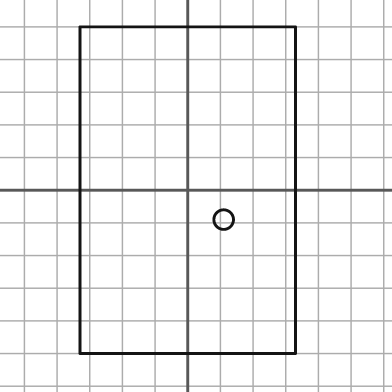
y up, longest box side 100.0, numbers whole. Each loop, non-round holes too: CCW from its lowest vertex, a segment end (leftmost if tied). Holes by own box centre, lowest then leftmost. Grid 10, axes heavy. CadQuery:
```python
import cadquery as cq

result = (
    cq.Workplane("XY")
    .moveTo(-33.0, -50.0)
    .lineTo(33.0, -50.0)
    .lineTo(33.0, 50.0)
    .lineTo(-33.0, 50.0)
    .close()
    .moveTo(11.0, -9.0)
    .circle(3.0)
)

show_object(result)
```